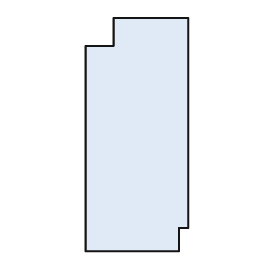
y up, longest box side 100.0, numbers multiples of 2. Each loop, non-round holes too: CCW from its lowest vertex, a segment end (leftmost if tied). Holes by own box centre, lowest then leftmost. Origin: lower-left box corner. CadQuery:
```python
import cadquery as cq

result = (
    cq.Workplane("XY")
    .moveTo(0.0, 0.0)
    .lineTo(40.0, 0.0)
    .lineTo(40.0, 10.0)
    .lineTo(44.0, 10.0)
    .lineTo(44.0, 100.0)
    .lineTo(12.0, 100.0)
    .lineTo(12.0, 88.0)
    .lineTo(0.0, 88.0)
    .close()
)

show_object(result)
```